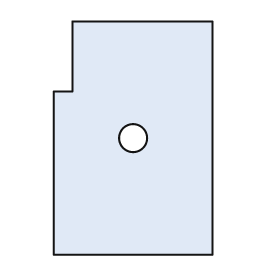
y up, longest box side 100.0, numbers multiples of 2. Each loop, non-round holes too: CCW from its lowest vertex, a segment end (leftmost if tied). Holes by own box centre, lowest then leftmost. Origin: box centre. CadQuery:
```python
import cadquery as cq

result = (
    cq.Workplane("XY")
    .moveTo(-34.0, -50.0)
    .lineTo(34.0, -50.0)
    .lineTo(34.0, 50.0)
    .lineTo(-26.0, 50.0)
    .lineTo(-26.0, 20.0)
    .lineTo(-34.0, 20.0)
    .close()
    .moveTo(0.0, 0.0)
    .circle(6.0)
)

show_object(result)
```